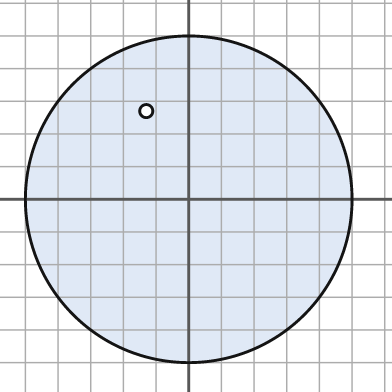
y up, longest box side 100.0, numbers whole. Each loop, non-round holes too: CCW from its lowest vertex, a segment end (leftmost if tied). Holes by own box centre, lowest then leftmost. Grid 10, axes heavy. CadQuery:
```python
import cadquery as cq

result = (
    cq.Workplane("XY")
    .moveTo(0.0, 0.0)
    .circle(50.0)
    .moveTo(-13.0, 27.0)
    .circle(2.0)
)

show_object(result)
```